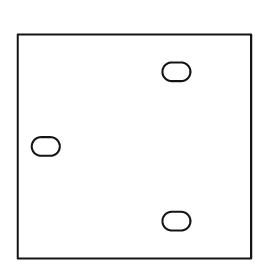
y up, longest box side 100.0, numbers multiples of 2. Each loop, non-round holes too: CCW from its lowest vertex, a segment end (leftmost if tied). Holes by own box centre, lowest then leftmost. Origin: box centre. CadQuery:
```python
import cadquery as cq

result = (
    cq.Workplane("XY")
    .moveTo(-50.0, -48.0)
    .lineTo(50.0, -48.0)
    .lineTo(50.0, 48.0)
    .lineTo(-50.0, 48.0)
    .close()
    .moveTo(16.0, -36.0)
    .lineTo(20.0, -36.0)
    .threePointArc((24.0, -32.0), (20.0, -28.0))
    .lineTo(16.0, -28.0)
    .threePointArc((12.0, -32.0), (16.0, -36.0))
    .close()
    .moveTo(-40.0, -4.0)
    .lineTo(-36.0, -4.0)
    .threePointArc((-32.0, 0.0), (-36.0, 4.0))
    .lineTo(-40.0, 4.0)
    .threePointArc((-44.0, 0.0), (-40.0, -4.0))
    .close()
    .moveTo(16.0, 28.0)
    .lineTo(20.0, 28.0)
    .threePointArc((24.0, 32.0), (20.0, 36.0))
    .lineTo(16.0, 36.0)
    .threePointArc((12.0, 32.0), (16.0, 28.0))
    .close()
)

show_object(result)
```